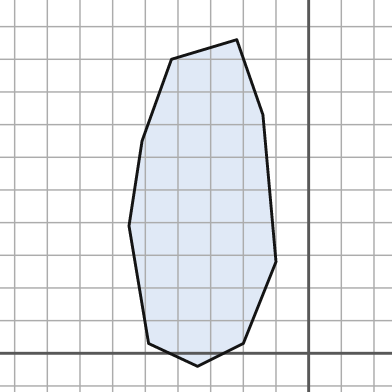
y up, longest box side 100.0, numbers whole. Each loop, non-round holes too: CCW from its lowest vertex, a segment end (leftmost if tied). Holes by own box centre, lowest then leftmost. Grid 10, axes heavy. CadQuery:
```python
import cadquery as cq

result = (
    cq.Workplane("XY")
    .moveTo(-34.0, -4.0)
    .lineTo(-20.0, 3.0)
    .lineTo(-10.0, 28.0)
    .lineTo(-14.0, 73.0)
    .lineTo(-22.0, 96.0)
    .lineTo(-42.0, 90.0)
    .lineTo(-51.0, 65.0)
    .lineTo(-55.0, 39.0)
    .lineTo(-49.0, 3.0)
    .close()
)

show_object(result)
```